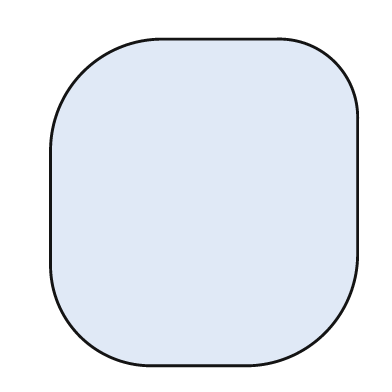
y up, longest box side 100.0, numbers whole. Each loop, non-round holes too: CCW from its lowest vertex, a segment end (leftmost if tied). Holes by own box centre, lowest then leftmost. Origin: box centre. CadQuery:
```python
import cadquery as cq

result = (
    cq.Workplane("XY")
    .moveTo(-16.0, -50.0)
    .lineTo(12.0, -50.0)
    .threePointArc((37.0, -40.0), (47.0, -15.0))
    .lineTo(47.0, 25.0)
    .threePointArc((40.0, 43.0), (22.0, 50.0))
    .lineTo(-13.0, 50.0)
    .threePointArc((-37.0, 40.0), (-47.0, 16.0))
    .lineTo(-47.0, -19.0)
    .threePointArc((-38.0, -41.0), (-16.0, -50.0))
    .close()
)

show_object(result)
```